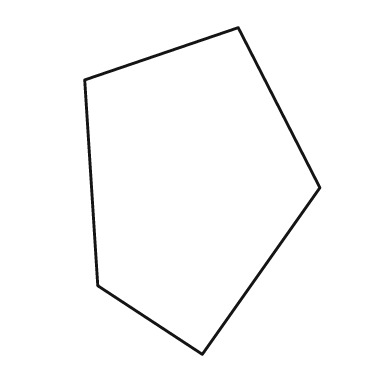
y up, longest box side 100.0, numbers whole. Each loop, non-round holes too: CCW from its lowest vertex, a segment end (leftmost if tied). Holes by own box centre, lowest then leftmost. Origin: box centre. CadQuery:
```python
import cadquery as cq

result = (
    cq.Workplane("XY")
    .moveTo(0.0, -50.0)
    .lineTo(36.0, 1.0)
    .lineTo(11.0, 50.0)
    .lineTo(-36.0, 34.0)
    .lineTo(-32.0, -29.0)
    .close()
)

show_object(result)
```